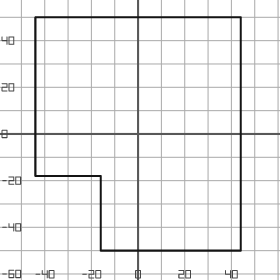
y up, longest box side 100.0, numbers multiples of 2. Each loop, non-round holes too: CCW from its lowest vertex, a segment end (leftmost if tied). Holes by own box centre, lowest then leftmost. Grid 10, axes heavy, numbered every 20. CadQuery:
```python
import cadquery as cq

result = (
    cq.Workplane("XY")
    .moveTo(-16.0, -50.0)
    .lineTo(44.0, -50.0)
    .lineTo(44.0, 50.0)
    .lineTo(-44.0, 50.0)
    .lineTo(-44.0, -18.0)
    .lineTo(-16.0, -18.0)
    .close()
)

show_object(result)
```